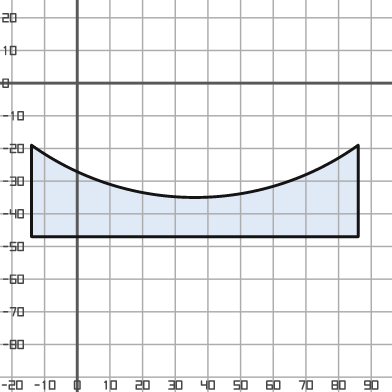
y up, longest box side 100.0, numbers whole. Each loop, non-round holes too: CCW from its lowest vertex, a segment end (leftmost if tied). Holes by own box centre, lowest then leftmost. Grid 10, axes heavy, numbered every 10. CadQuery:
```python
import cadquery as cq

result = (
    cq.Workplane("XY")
    .moveTo(-14.0, -47.0)
    .lineTo(86.0, -47.0)
    .lineTo(86.0, -19.0)
    .threePointArc((36.0, -35.0), (-14.0, -19.0))
    .close()
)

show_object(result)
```